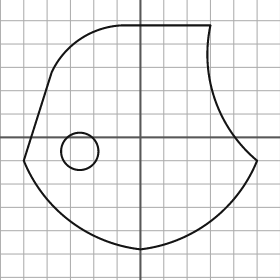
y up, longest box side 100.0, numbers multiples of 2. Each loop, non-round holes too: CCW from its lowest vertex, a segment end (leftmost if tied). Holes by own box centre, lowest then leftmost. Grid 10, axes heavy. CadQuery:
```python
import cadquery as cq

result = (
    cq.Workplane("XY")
    .moveTo(0.0, -48.0)
    .threePointArc((30.0, -36.0), (50.0, -10.0))
    .threePointArc((32.0, 16.0), (30.0, 48.0))
    .lineTo(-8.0, 48.0)
    .threePointArc((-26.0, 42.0), (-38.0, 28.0))
    .lineTo(-50.0, -10.0)
    .threePointArc((-30.0, -36.0), (0.0, -48.0))
    .close()
    .moveTo(-26.0, -6.0)
    .circle(8.0)
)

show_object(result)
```